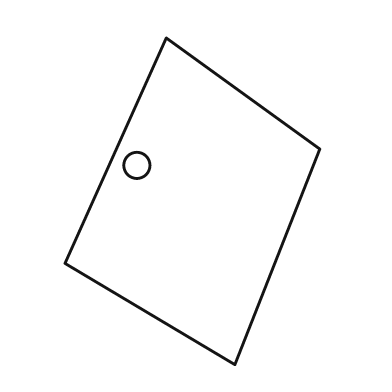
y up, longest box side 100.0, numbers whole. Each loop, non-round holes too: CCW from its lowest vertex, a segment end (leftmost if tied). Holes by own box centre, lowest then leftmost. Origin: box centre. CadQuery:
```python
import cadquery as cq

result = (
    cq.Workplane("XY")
    .moveTo(13.0, -50.0)
    .lineTo(39.0, 16.0)
    .lineTo(-8.0, 50.0)
    .lineTo(-39.0, -19.0)
    .close()
    .moveTo(-17.0, 11.0)
    .circle(4.0)
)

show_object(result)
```